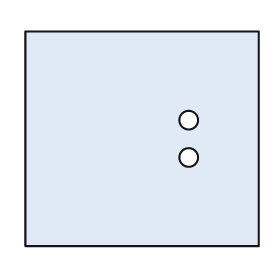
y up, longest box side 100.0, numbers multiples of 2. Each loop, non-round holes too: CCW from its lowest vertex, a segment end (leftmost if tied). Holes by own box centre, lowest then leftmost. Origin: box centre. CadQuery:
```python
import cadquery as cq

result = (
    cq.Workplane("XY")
    .moveTo(-50.0, -46.0)
    .lineTo(50.0, -46.0)
    .lineTo(50.0, 46.0)
    .lineTo(-50.0, 46.0)
    .close()
    .moveTo(20.0, -8.0)
    .circle(4.0)
    .moveTo(20.0, 8.0)
    .circle(4.0)
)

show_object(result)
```